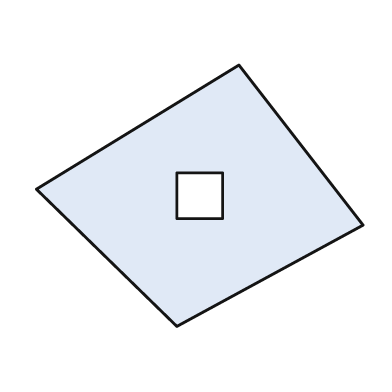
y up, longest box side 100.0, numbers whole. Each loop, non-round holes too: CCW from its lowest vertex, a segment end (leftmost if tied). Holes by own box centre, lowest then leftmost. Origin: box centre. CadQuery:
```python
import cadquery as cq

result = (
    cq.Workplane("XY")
    .moveTo(-7.0, -40.0)
    .lineTo(50.0, -9.0)
    .lineTo(12.0, 40.0)
    .lineTo(-50.0, 2.0)
    .close()
    .moveTo(-7.0, -7.0)
    .lineTo(7.0, -7.0)
    .lineTo(7.0, 7.0)
    .lineTo(-7.0, 7.0)
    .close()
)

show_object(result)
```